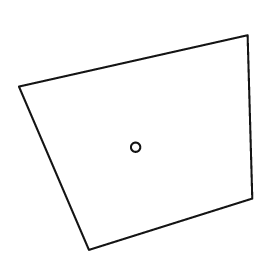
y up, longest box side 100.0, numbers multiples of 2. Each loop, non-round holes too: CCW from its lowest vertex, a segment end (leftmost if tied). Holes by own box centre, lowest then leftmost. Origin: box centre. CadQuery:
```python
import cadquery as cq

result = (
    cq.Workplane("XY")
    .moveTo(-20.0, -46.0)
    .lineTo(50.0, -24.0)
    .lineTo(48.0, 46.0)
    .lineTo(-50.0, 24.0)
    .close()
    .moveTo(0.0, -2.0)
    .circle(2.0)
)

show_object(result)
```